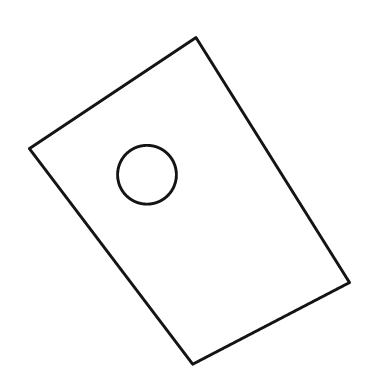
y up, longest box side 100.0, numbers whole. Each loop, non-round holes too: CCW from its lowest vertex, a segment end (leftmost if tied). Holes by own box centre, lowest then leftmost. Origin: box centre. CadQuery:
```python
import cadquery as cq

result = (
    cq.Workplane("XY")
    .moveTo(1.0, -50.0)
    .lineTo(49.0, -25.0)
    .lineTo(2.0, 50.0)
    .lineTo(-49.0, 16.0)
    .close()
    .moveTo(-13.0, 8.0)
    .circle(9.0)
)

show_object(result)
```